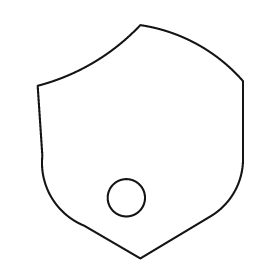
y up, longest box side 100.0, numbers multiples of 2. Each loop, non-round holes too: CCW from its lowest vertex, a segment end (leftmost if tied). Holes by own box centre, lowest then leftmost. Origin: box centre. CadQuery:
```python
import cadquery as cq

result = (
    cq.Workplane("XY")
    .moveTo(0.0, -50.0)
    .lineTo(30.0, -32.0)
    .threePointArc((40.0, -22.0), (44.0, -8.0))
    .lineTo(44.0, 26.0)
    .threePointArc((24.0, 42.0), (0.0, 50.0))
    .threePointArc((-20.0, 34.0), (-44.0, 24.0))
    .lineTo(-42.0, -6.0)
    .threePointArc((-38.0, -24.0), (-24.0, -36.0))
    .close()
    .moveTo(-6.0, -24.0)
    .circle(8.0)
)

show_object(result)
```